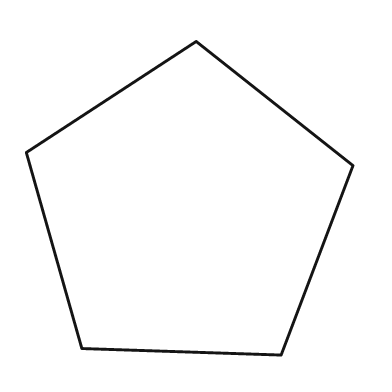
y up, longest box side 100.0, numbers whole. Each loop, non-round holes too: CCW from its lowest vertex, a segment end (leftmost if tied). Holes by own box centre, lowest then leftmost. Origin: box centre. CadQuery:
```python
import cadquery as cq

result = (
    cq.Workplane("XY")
    .moveTo(28.0, -48.0)
    .lineTo(50.0, 10.0)
    .lineTo(2.0, 48.0)
    .lineTo(-50.0, 14.0)
    .lineTo(-33.0, -46.0)
    .close()
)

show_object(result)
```